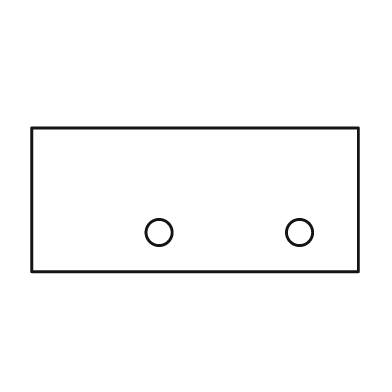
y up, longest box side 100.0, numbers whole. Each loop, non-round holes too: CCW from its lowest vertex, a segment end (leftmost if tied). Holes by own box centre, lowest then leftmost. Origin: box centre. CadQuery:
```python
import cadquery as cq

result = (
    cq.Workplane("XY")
    .moveTo(-50.0, -22.0)
    .lineTo(50.0, -22.0)
    .lineTo(50.0, 22.0)
    .lineTo(-50.0, 22.0)
    .close()
    .moveTo(-11.0, -10.0)
    .circle(4.0)
    .moveTo(32.0, -10.0)
    .circle(4.0)
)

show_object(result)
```